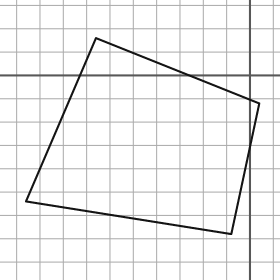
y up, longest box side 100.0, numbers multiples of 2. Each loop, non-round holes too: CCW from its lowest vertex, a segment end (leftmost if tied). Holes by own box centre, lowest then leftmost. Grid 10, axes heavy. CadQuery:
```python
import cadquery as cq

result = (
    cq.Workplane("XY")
    .moveTo(-8.0, -68.0)
    .lineTo(4.0, -12.0)
    .lineTo(-66.0, 16.0)
    .lineTo(-96.0, -54.0)
    .close()
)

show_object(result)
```